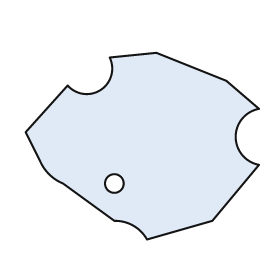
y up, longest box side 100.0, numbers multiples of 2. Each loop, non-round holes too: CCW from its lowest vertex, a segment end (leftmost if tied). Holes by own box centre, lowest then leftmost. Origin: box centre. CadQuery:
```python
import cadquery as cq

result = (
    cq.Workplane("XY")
    .moveTo(2.0, -40.0)
    .lineTo(30.0, -32.0)
    .lineTo(50.0, -8.0)
    .threePointArc((40.0, 4.0), (50.0, 16.0))
    .lineTo(36.0, 28.0)
    .lineTo(6.0, 40.0)
    .lineTo(-14.0, 38.0)
    .threePointArc((-18.0, 24.0), (-32.0, 26.0))
    .lineTo(-50.0, 6.0)
    .lineTo(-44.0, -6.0)
    .threePointArc((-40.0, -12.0), (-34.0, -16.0))
    .lineTo(-12.0, -32.0)
    .threePointArc((-4.0, -34.0), (2.0, -40.0))
    .close()
    .moveTo(-12.0, -16.0)
    .circle(4.0)
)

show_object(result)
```